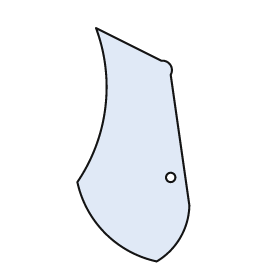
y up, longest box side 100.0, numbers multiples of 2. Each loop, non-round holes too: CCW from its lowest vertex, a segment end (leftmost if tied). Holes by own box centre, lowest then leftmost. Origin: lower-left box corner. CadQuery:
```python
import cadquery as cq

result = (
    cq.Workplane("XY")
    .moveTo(34.0, 0.0)
    .threePointArc((44.0, 10.0), (48.0, 24.0))
    .lineTo(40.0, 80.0)
    .threePointArc((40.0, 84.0), (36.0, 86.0))
    .lineTo(8.0, 100.0)
    .threePointArc((12.0, 66.0), (0.0, 34.0))
    .threePointArc((12.0, 12.0), (34.0, 0.0))
    .close()
    .moveTo(40.0, 36.0)
    .circle(2.0)
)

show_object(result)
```